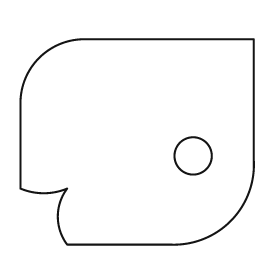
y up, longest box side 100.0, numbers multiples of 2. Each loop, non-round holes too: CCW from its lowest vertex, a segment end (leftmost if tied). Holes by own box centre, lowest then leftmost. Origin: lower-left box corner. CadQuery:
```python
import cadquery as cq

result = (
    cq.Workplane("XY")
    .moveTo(20.0, 0.0)
    .lineTo(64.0, 0.0)
    .threePointArc((90.0, 10.0), (100.0, 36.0))
    .lineTo(100.0, 88.0)
    .lineTo(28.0, 88.0)
    .threePointArc((8.0, 80.0), (0.0, 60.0))
    .lineTo(0.0, 24.0)
    .threePointArc((10.0, 22.0), (20.0, 24.0))
    .threePointArc((16.0, 12.0), (20.0, 0.0))
    .close()
    .moveTo(74.0, 38.0)
    .circle(8.0)
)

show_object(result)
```